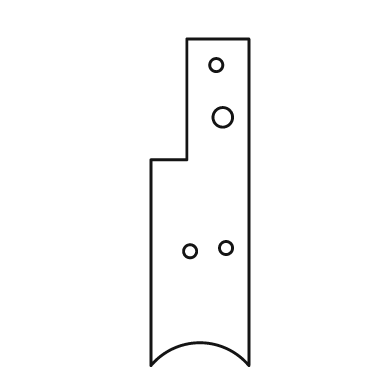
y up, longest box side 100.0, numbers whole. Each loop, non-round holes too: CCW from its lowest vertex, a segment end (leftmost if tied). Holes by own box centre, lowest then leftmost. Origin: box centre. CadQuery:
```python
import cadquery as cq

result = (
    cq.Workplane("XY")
    .moveTo(-15.0, -50.0)
    .threePointArc((0.0, -43.0), (15.0, -50.0))
    .lineTo(15.0, 50.0)
    .lineTo(-4.0, 50.0)
    .lineTo(-4.0, 13.0)
    .lineTo(-15.0, 13.0)
    .close()
    .moveTo(-3.0, -15.0)
    .circle(2.0)
    .moveTo(8.0, -14.0)
    .circle(2.0)
    .moveTo(7.0, 26.0)
    .circle(3.0)
    .moveTo(5.0, 42.0)
    .circle(2.0)
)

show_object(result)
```